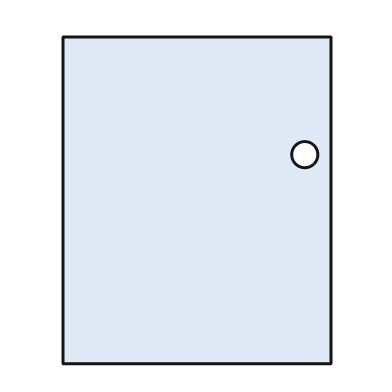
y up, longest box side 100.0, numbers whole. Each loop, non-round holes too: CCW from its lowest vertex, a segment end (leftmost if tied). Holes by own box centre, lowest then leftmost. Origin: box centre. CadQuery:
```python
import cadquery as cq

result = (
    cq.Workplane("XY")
    .moveTo(-41.0, -50.0)
    .lineTo(41.0, -50.0)
    .lineTo(41.0, 50.0)
    .lineTo(-41.0, 50.0)
    .close()
    .moveTo(33.0, 14.0)
    .circle(4.0)
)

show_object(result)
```